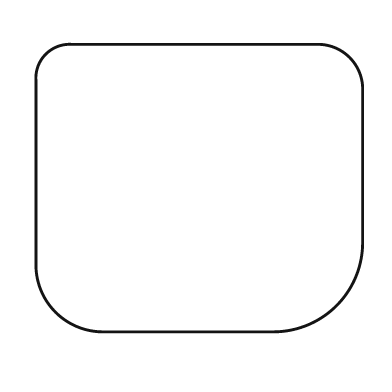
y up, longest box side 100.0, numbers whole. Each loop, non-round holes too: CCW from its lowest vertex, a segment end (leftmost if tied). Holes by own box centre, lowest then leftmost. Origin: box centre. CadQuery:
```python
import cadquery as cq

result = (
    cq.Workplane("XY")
    .moveTo(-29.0, -44.0)
    .lineTo(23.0, -44.0)
    .threePointArc((42.0, -36.0), (50.0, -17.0))
    .lineTo(50.0, 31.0)
    .threePointArc((46.0, 40.0), (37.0, 44.0))
    .lineTo(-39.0, 44.0)
    .threePointArc((-47.0, 41.0), (-50.0, 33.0))
    .lineTo(-50.0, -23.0)
    .threePointArc((-44.0, -38.0), (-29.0, -44.0))
    .close()
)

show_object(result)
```